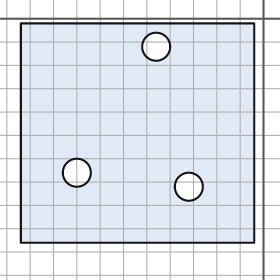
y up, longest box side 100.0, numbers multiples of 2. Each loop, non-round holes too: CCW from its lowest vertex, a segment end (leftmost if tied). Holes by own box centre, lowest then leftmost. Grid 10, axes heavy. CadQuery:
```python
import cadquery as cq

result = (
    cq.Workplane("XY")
    .moveTo(-104.0, -96.0)
    .lineTo(-4.0, -96.0)
    .lineTo(-4.0, -2.0)
    .lineTo(-104.0, -2.0)
    .close()
    .moveTo(-32.0, -72.0)
    .circle(6.0)
    .moveTo(-80.0, -66.0)
    .circle(6.0)
    .moveTo(-46.0, -12.0)
    .circle(6.0)
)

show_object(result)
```